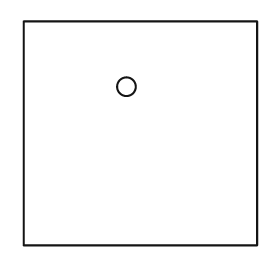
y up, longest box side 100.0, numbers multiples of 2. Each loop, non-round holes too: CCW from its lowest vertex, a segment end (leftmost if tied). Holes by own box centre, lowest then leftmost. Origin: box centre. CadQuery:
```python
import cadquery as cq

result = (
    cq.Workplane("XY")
    .moveTo(-50.0, -48.0)
    .lineTo(50.0, -48.0)
    .lineTo(50.0, 48.0)
    .lineTo(-50.0, 48.0)
    .close()
    .moveTo(-6.0, 20.0)
    .circle(4.0)
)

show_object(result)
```